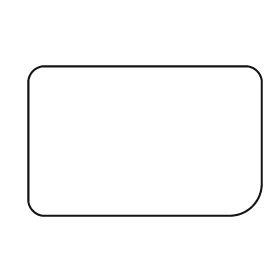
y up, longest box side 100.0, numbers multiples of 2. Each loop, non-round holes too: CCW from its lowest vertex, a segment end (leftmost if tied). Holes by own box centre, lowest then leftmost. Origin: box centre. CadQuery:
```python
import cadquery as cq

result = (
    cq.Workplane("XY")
    .moveTo(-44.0, -32.0)
    .lineTo(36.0, -32.0)
    .threePointArc((46.0, -28.0), (50.0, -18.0))
    .lineTo(50.0, 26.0)
    .threePointArc((48.0, 30.0), (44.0, 32.0))
    .lineTo(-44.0, 32.0)
    .threePointArc((-48.0, 30.0), (-50.0, 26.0))
    .lineTo(-50.0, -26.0)
    .threePointArc((-48.0, -30.0), (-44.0, -32.0))
    .close()
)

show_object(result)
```